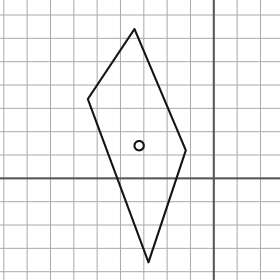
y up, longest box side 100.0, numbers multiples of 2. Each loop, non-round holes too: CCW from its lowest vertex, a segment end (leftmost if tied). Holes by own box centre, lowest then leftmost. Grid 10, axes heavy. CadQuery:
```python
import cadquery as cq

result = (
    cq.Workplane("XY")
    .moveTo(-28.0, -36.0)
    .lineTo(-12.0, 12.0)
    .lineTo(-34.0, 64.0)
    .lineTo(-54.0, 34.0)
    .close()
    .moveTo(-32.0, 14.0)
    .circle(2.0)
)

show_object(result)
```